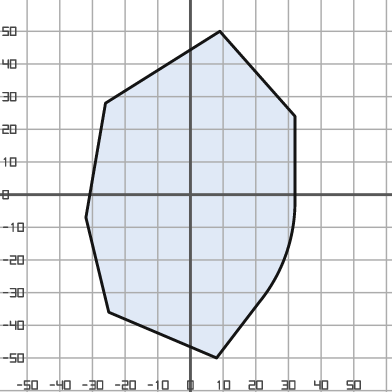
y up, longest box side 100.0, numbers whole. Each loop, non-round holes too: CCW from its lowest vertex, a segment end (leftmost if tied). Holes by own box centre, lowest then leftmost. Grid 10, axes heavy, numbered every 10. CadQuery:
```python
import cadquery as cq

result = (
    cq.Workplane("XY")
    .moveTo(8.0, -50.0)
    .lineTo(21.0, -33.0)
    .threePointArc((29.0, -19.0), (32.0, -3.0))
    .lineTo(32.0, 24.0)
    .lineTo(9.0, 50.0)
    .lineTo(-26.0, 28.0)
    .lineTo(-32.0, -7.0)
    .lineTo(-25.0, -36.0)
    .close()
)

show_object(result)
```